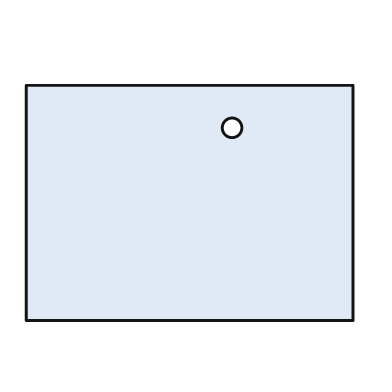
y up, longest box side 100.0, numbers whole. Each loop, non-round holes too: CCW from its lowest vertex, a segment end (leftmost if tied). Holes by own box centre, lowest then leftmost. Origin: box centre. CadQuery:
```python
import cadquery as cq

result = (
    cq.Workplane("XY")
    .moveTo(-50.0, -36.0)
    .lineTo(50.0, -36.0)
    .lineTo(50.0, 36.0)
    .lineTo(-50.0, 36.0)
    .close()
    .moveTo(13.0, 23.0)
    .circle(3.0)
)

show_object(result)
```